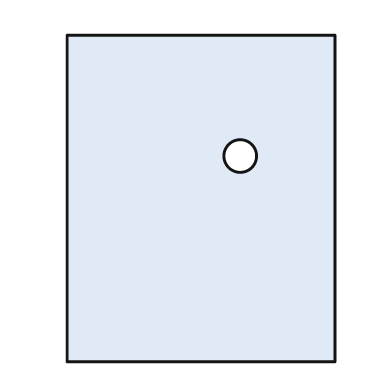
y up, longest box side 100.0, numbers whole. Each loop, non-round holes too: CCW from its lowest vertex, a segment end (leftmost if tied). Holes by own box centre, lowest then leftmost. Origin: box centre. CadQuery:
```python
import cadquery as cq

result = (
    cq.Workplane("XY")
    .moveTo(-41.0, -50.0)
    .lineTo(41.0, -50.0)
    .lineTo(41.0, 50.0)
    .lineTo(-41.0, 50.0)
    .close()
    .moveTo(12.0, 13.0)
    .circle(5.0)
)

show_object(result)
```